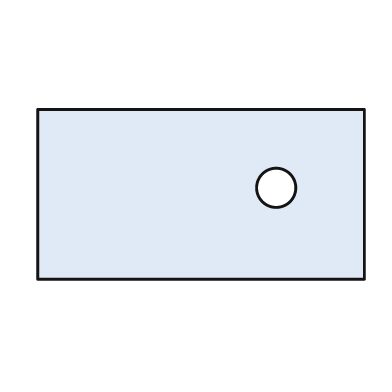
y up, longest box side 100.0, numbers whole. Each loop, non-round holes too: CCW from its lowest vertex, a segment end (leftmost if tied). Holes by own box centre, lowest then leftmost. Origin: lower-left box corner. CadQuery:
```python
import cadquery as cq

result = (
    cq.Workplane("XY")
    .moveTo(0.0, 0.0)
    .lineTo(100.0, 0.0)
    .lineTo(100.0, 52.0)
    .lineTo(0.0, 52.0)
    .close()
    .moveTo(73.0, 28.0)
    .circle(6.0)
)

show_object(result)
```